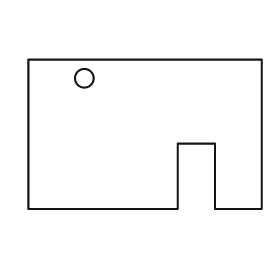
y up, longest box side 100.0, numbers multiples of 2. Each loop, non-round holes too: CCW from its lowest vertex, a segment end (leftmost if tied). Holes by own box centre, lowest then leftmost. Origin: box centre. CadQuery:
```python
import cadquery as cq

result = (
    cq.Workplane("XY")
    .moveTo(-50.0, -32.0)
    .lineTo(14.0, -32.0)
    .lineTo(14.0, -4.0)
    .lineTo(30.0, -4.0)
    .lineTo(30.0, -32.0)
    .lineTo(50.0, -32.0)
    .lineTo(50.0, 32.0)
    .lineTo(-50.0, 32.0)
    .close()
    .moveTo(-26.0, 24.0)
    .circle(4.0)
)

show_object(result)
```